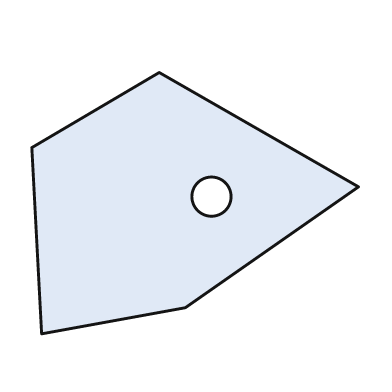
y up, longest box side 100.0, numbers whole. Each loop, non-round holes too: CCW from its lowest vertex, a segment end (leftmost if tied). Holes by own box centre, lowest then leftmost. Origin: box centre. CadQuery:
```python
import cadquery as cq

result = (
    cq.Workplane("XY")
    .moveTo(-47.0, -40.0)
    .lineTo(-3.0, -32.0)
    .lineTo(50.0, 5.0)
    .lineTo(-11.0, 40.0)
    .lineTo(-50.0, 17.0)
    .close()
    .moveTo(5.0, 2.0)
    .circle(6.0)
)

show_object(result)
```